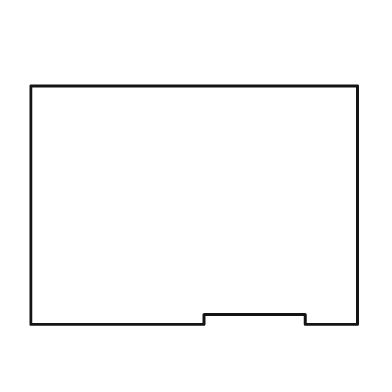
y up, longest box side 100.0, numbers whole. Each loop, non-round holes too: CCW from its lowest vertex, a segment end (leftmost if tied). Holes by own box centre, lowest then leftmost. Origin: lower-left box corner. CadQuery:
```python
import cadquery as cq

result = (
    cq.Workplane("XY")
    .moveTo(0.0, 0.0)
    .lineTo(53.0, 0.0)
    .lineTo(53.0, 3.0)
    .lineTo(84.0, 3.0)
    .lineTo(84.0, 0.0)
    .lineTo(100.0, 0.0)
    .lineTo(100.0, 73.0)
    .lineTo(0.0, 73.0)
    .close()
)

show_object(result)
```